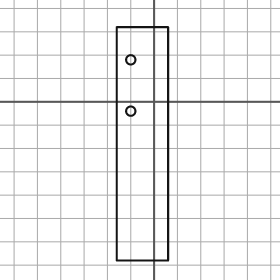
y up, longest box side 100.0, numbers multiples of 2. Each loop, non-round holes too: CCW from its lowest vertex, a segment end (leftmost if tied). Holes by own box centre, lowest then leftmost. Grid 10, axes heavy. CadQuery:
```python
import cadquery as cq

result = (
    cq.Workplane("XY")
    .moveTo(-16.0, -68.0)
    .lineTo(6.0, -68.0)
    .lineTo(6.0, 32.0)
    .lineTo(-16.0, 32.0)
    .close()
    .moveTo(-10.0, -4.0)
    .circle(2.0)
    .moveTo(-10.0, 18.0)
    .circle(2.0)
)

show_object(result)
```